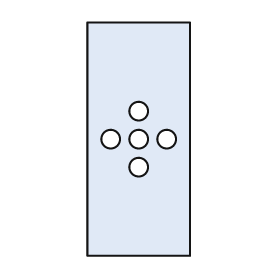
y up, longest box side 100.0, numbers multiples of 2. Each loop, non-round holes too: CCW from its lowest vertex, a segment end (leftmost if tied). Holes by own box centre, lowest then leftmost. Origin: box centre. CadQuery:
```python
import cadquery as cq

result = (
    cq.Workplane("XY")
    .moveTo(-22.0, -50.0)
    .lineTo(22.0, -50.0)
    .lineTo(22.0, 50.0)
    .lineTo(-22.0, 50.0)
    .close()
    .moveTo(0.0, -12.0)
    .circle(4.0)
    .moveTo(-12.0, 0.0)
    .circle(4.0)
    .moveTo(0.0, 0.0)
    .circle(4.0)
    .moveTo(12.0, 0.0)
    .circle(4.0)
    .moveTo(0.0, 12.0)
    .circle(4.0)
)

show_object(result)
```